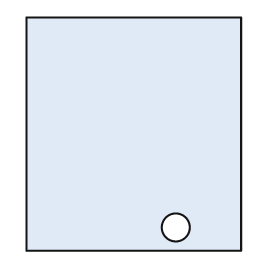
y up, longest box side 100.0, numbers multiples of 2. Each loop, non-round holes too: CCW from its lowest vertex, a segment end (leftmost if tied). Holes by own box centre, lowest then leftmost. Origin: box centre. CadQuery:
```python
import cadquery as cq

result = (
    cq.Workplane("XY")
    .moveTo(-46.0, -50.0)
    .lineTo(46.0, -50.0)
    .lineTo(46.0, 50.0)
    .lineTo(-46.0, 50.0)
    .close()
    .moveTo(18.0, -40.0)
    .circle(6.0)
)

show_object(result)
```